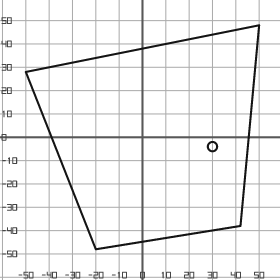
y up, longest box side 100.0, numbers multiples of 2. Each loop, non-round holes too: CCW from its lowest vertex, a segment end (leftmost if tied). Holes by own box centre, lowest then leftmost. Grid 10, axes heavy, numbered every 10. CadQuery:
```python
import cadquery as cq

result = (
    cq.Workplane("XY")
    .moveTo(-20.0, -48.0)
    .lineTo(42.0, -38.0)
    .lineTo(50.0, 48.0)
    .lineTo(-50.0, 28.0)
    .close()
    .moveTo(30.0, -4.0)
    .circle(2.0)
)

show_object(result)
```